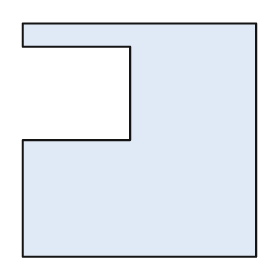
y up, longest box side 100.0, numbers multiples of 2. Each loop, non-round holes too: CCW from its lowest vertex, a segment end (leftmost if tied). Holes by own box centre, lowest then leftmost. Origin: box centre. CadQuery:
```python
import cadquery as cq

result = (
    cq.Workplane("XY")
    .moveTo(-50.0, -50.0)
    .lineTo(50.0, -50.0)
    .lineTo(50.0, 50.0)
    .lineTo(-50.0, 50.0)
    .lineTo(-50.0, 40.0)
    .lineTo(-4.0, 40.0)
    .lineTo(-4.0, 0.0)
    .lineTo(-50.0, 0.0)
    .close()
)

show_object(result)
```